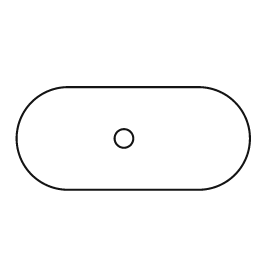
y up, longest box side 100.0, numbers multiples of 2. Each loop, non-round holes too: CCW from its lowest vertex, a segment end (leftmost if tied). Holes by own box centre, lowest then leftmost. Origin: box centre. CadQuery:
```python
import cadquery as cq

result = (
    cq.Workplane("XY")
    .moveTo(-28.0, -22.0)
    .lineTo(28.0, -22.0)
    .threePointArc((50.0, 0.0), (28.0, 22.0))
    .lineTo(-28.0, 22.0)
    .threePointArc((-50.0, 0.0), (-28.0, -22.0))
    .close()
    .moveTo(-4.0, 0.0)
    .circle(4.0)
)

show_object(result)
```